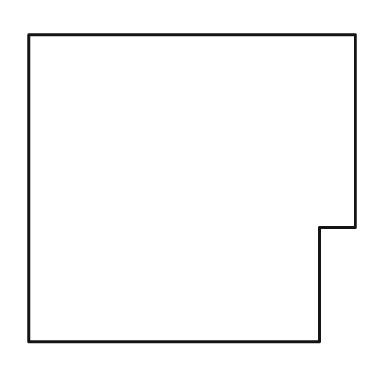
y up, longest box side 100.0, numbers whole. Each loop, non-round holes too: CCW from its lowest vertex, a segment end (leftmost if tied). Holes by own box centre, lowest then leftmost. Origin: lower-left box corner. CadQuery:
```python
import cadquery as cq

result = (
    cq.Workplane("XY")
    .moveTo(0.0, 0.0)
    .lineTo(89.0, 0.0)
    .lineTo(89.0, 35.0)
    .lineTo(100.0, 35.0)
    .lineTo(100.0, 94.0)
    .lineTo(0.0, 94.0)
    .close()
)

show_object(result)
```